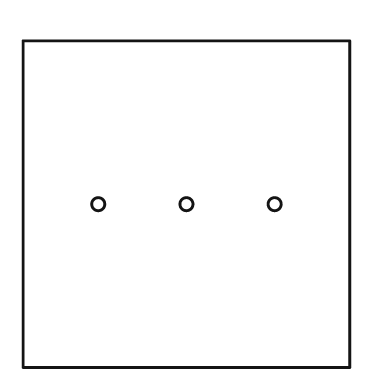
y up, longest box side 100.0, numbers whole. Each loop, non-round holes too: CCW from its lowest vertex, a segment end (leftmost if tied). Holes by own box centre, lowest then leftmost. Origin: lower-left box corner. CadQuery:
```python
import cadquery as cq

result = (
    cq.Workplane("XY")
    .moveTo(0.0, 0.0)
    .lineTo(100.0, 0.0)
    .lineTo(100.0, 100.0)
    .lineTo(0.0, 100.0)
    .close()
    .moveTo(23.0, 50.0)
    .circle(2.0)
    .moveTo(50.0, 50.0)
    .circle(2.0)
    .moveTo(77.0, 50.0)
    .circle(2.0)
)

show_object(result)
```